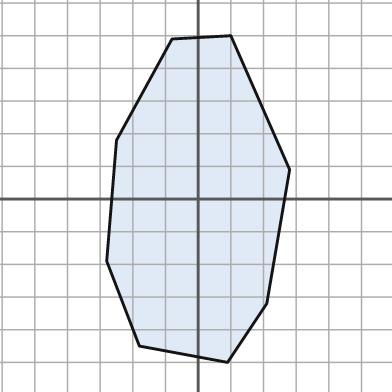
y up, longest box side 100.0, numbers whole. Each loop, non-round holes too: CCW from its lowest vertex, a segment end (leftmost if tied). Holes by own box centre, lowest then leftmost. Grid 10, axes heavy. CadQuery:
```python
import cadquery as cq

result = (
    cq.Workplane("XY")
    .moveTo(9.0, -50.0)
    .lineTo(21.0, -32.0)
    .lineTo(28.0, 9.0)
    .lineTo(10.0, 50.0)
    .lineTo(-8.0, 49.0)
    .lineTo(-25.0, 18.0)
    .lineTo(-28.0, -19.0)
    .lineTo(-18.0, -45.0)
    .close()
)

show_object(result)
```